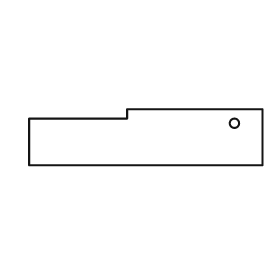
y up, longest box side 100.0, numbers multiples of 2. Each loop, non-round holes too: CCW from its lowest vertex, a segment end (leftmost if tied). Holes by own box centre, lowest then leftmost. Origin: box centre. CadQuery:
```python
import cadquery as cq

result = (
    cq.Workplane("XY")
    .moveTo(-50.0, -12.0)
    .lineTo(50.0, -12.0)
    .lineTo(50.0, 12.0)
    .lineTo(-8.0, 12.0)
    .lineTo(-8.0, 8.0)
    .lineTo(-50.0, 8.0)
    .close()
    .moveTo(38.0, 6.0)
    .circle(2.0)
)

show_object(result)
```